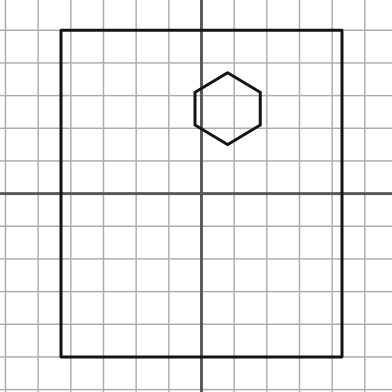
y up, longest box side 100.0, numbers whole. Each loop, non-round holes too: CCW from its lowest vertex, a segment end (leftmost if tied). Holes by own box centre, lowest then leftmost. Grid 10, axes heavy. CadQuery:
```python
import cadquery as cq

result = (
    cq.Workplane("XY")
    .moveTo(-43.0, -50.0)
    .lineTo(43.0, -50.0)
    .lineTo(43.0, 50.0)
    .lineTo(-43.0, 50.0)
    .close()
    .moveTo(8.0, 15.0)
    .lineTo(18.0, 21.0)
    .lineTo(18.0, 31.0)
    .lineTo(8.0, 37.0)
    .lineTo(-2.0, 31.0)
    .lineTo(-2.0, 21.0)
    .close()
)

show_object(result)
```